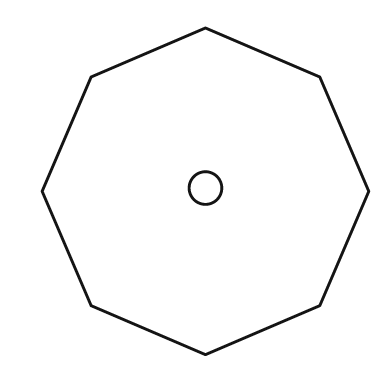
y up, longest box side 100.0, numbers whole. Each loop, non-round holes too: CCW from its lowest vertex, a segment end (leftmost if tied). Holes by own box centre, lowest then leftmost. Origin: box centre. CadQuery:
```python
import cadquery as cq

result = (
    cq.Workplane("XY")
    .moveTo(0.0, -50.0)
    .lineTo(35.0, -35.0)
    .lineTo(50.0, 0.0)
    .lineTo(35.0, 35.0)
    .lineTo(0.0, 50.0)
    .lineTo(-35.0, 35.0)
    .lineTo(-50.0, 0.0)
    .lineTo(-35.0, -35.0)
    .close()
    .moveTo(0.0, 1.0)
    .circle(5.0)
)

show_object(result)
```